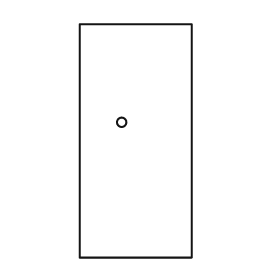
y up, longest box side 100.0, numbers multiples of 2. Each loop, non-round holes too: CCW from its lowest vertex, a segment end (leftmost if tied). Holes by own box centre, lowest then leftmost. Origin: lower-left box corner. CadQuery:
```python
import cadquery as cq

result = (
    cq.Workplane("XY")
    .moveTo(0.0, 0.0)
    .lineTo(48.0, 0.0)
    .lineTo(48.0, 100.0)
    .lineTo(0.0, 100.0)
    .close()
    .moveTo(18.0, 58.0)
    .circle(2.0)
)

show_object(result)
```